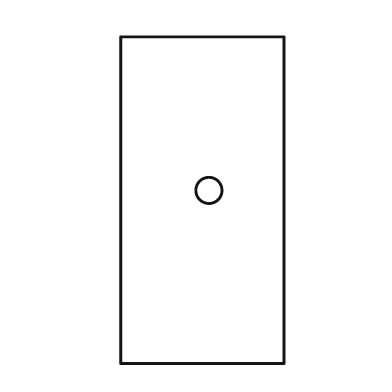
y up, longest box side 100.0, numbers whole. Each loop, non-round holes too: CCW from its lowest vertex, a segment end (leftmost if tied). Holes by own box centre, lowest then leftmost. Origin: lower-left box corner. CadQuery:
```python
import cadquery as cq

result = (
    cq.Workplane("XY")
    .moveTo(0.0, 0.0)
    .lineTo(50.0, 0.0)
    .lineTo(50.0, 100.0)
    .lineTo(0.0, 100.0)
    .close()
    .moveTo(27.0, 53.0)
    .circle(4.0)
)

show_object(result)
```